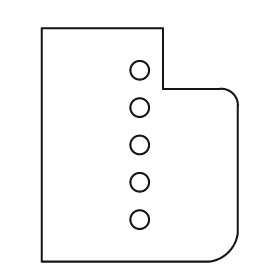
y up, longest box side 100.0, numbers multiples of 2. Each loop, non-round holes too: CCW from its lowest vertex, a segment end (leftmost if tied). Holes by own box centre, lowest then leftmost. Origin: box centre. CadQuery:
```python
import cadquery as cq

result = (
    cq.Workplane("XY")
    .moveTo(-42.0, -50.0)
    .lineTo(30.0, -50.0)
    .threePointArc((38.0, -46.0), (42.0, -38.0))
    .lineTo(42.0, 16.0)
    .threePointArc((40.0, 22.0), (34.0, 24.0))
    .lineTo(10.0, 24.0)
    .lineTo(10.0, 50.0)
    .lineTo(-42.0, 50.0)
    .close()
    .moveTo(0.0, -32.0)
    .circle(4.0)
    .moveTo(0.0, -16.0)
    .circle(4.0)
    .moveTo(0.0, 0.0)
    .circle(4.0)
    .moveTo(0.0, 16.0)
    .circle(4.0)
    .moveTo(0.0, 32.0)
    .circle(4.0)
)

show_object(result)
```